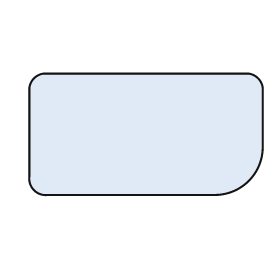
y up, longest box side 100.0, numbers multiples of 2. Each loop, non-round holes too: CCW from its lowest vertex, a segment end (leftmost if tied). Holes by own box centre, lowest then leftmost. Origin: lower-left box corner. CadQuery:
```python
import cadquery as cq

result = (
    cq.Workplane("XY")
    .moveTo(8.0, 0.0)
    .lineTo(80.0, 0.0)
    .threePointArc((94.0, 6.0), (100.0, 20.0))
    .lineTo(100.0, 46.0)
    .threePointArc((98.0, 50.0), (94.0, 52.0))
    .lineTo(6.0, 52.0)
    .threePointArc((2.0, 50.0), (0.0, 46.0))
    .lineTo(0.0, 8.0)
    .threePointArc((2.0, 2.0), (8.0, 0.0))
    .close()
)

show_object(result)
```